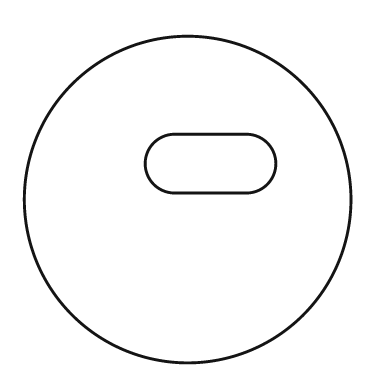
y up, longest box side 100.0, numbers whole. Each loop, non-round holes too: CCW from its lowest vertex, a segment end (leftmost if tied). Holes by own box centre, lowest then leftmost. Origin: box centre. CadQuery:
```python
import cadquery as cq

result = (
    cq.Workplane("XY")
    .moveTo(0.0, 0.0)
    .circle(50.0)
    .moveTo(-4.0, 2.0)
    .lineTo(18.0, 2.0)
    .threePointArc((27.0, 11.0), (18.0, 20.0))
    .lineTo(-4.0, 20.0)
    .threePointArc((-13.0, 11.0), (-4.0, 2.0))
    .close()
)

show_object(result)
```